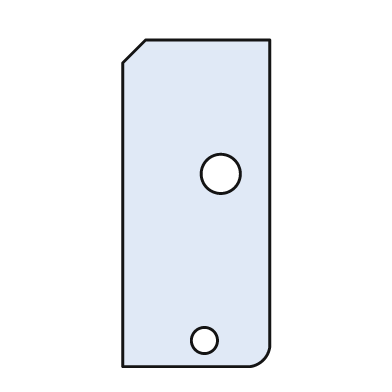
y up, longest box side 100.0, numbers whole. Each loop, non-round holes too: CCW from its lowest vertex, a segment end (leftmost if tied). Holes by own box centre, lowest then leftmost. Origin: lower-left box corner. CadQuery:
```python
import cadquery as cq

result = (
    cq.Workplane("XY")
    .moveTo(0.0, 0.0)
    .lineTo(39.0, 0.0)
    .threePointArc((43.0, 2.0), (45.0, 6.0))
    .lineTo(45.0, 100.0)
    .lineTo(7.0, 100.0)
    .lineTo(0.0, 93.0)
    .close()
    .moveTo(25.0, 8.0)
    .circle(4.0)
    .moveTo(30.0, 59.0)
    .circle(6.0)
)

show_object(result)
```